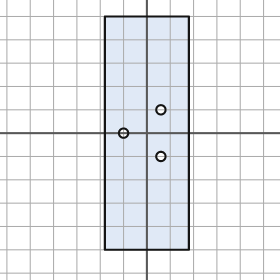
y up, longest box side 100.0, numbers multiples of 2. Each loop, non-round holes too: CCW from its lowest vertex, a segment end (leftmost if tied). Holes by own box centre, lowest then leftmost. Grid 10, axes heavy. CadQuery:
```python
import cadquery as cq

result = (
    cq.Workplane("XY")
    .moveTo(-18.0, -50.0)
    .lineTo(18.0, -50.0)
    .lineTo(18.0, 50.0)
    .lineTo(-18.0, 50.0)
    .close()
    .moveTo(6.0, -10.0)
    .circle(2.0)
    .moveTo(-10.0, 0.0)
    .circle(2.0)
    .moveTo(6.0, 10.0)
    .circle(2.0)
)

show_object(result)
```